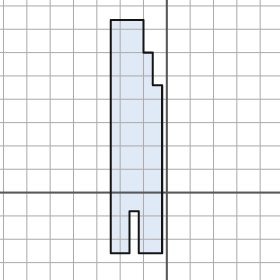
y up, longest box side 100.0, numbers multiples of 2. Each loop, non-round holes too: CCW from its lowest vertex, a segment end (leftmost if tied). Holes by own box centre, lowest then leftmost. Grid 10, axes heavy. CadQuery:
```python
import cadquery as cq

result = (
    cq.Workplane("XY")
    .moveTo(-24.0, -26.0)
    .lineTo(-16.0, -26.0)
    .lineTo(-16.0, -8.0)
    .lineTo(-12.0, -8.0)
    .lineTo(-12.0, -26.0)
    .lineTo(-2.0, -26.0)
    .lineTo(-2.0, 46.0)
    .lineTo(-6.0, 46.0)
    .lineTo(-6.0, 60.0)
    .lineTo(-10.0, 60.0)
    .lineTo(-10.0, 74.0)
    .lineTo(-24.0, 74.0)
    .close()
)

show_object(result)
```